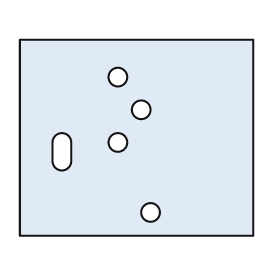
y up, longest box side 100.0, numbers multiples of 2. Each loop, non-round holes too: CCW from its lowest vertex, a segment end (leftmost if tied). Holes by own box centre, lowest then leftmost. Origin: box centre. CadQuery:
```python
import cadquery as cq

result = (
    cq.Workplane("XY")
    .moveTo(-50.0, -42.0)
    .lineTo(50.0, -42.0)
    .lineTo(50.0, 42.0)
    .lineTo(-50.0, 42.0)
    .close()
    .moveTo(6.0, -32.0)
    .circle(4.0)
    .moveTo(-36.0, -10.0)
    .threePointArc((-32.0, -14.0), (-28.0, -10.0))
    .lineTo(-28.0, -2.0)
    .threePointArc((-32.0, 2.0), (-36.0, -2.0))
    .close()
    .moveTo(-8.0, -2.0)
    .circle(4.0)
    .moveTo(2.0, 12.0)
    .circle(4.0)
    .moveTo(-8.0, 26.0)
    .circle(4.0)
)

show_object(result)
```